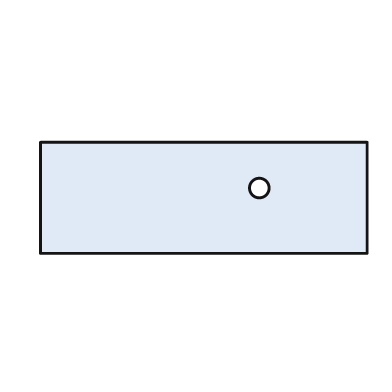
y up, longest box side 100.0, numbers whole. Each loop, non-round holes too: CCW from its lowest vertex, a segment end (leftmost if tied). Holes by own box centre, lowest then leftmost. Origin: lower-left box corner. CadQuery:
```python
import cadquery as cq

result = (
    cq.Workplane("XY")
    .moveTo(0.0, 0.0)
    .lineTo(100.0, 0.0)
    .lineTo(100.0, 34.0)
    .lineTo(0.0, 34.0)
    .close()
    .moveTo(67.0, 20.0)
    .circle(3.0)
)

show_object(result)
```